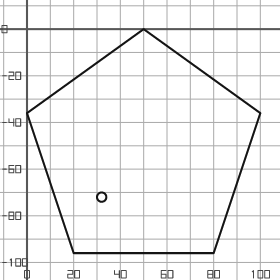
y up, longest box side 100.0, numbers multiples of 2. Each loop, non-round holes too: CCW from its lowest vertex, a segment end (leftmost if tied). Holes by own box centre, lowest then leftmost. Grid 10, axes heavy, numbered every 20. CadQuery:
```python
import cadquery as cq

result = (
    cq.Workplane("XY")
    .moveTo(20.0, -96.0)
    .lineTo(80.0, -96.0)
    .lineTo(100.0, -36.0)
    .lineTo(50.0, 0.0)
    .lineTo(0.0, -36.0)
    .close()
    .moveTo(32.0, -72.0)
    .circle(2.0)
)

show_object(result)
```